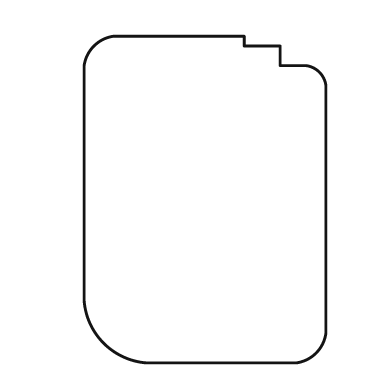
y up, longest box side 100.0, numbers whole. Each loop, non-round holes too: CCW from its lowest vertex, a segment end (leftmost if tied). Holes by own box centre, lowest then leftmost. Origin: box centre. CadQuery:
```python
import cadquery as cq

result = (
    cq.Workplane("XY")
    .moveTo(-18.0, -50.0)
    .lineTo(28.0, -50.0)
    .threePointArc((34.0, -47.0), (37.0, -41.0))
    .lineTo(37.0, 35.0)
    .threePointArc((35.0, 39.0), (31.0, 41.0))
    .lineTo(23.0, 41.0)
    .lineTo(23.0, 47.0)
    .lineTo(12.0, 47.0)
    .lineTo(12.0, 50.0)
    .lineTo(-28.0, 50.0)
    .threePointArc((-34.0, 47.0), (-37.0, 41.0))
    .lineTo(-37.0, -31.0)
    .threePointArc((-31.0, -44.0), (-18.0, -50.0))
    .close()
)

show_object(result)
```